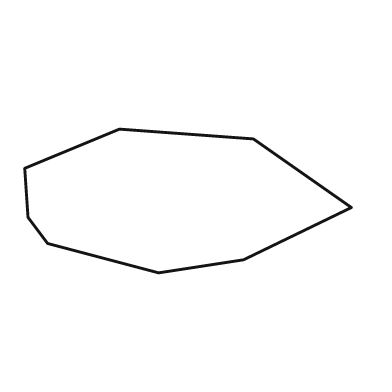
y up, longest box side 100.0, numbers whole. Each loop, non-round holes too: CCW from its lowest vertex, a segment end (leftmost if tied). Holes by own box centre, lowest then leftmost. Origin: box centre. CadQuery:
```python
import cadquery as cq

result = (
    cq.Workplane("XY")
    .moveTo(-9.0, -22.0)
    .lineTo(17.0, -18.0)
    .lineTo(50.0, -2.0)
    .lineTo(20.0, 19.0)
    .lineTo(-21.0, 22.0)
    .lineTo(-50.0, 10.0)
    .lineTo(-49.0, -5.0)
    .lineTo(-43.0, -13.0)
    .close()
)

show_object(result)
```